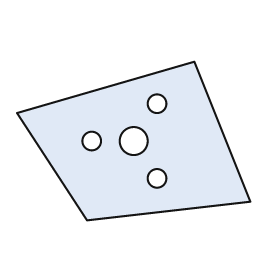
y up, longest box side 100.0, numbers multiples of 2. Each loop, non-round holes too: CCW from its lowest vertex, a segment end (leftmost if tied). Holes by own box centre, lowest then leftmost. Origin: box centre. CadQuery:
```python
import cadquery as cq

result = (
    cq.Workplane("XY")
    .moveTo(-20.0, -34.0)
    .lineTo(50.0, -26.0)
    .lineTo(26.0, 34.0)
    .lineTo(-50.0, 12.0)
    .close()
    .moveTo(10.0, -16.0)
    .circle(4.0)
    .moveTo(-18.0, 0.0)
    .circle(4.0)
    .moveTo(0.0, 0.0)
    .circle(6.0)
    .moveTo(10.0, 16.0)
    .circle(4.0)
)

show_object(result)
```